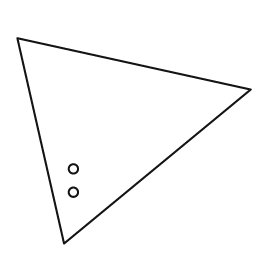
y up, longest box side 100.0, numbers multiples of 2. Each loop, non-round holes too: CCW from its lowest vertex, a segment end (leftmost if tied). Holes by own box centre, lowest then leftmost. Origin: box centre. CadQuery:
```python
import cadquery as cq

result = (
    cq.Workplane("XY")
    .moveTo(-30.0, -44.0)
    .lineTo(50.0, 22.0)
    .lineTo(-50.0, 44.0)
    .close()
    .moveTo(-26.0, -22.0)
    .circle(2.0)
    .moveTo(-26.0, -12.0)
    .circle(2.0)
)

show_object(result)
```